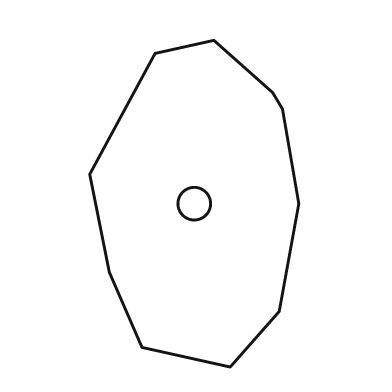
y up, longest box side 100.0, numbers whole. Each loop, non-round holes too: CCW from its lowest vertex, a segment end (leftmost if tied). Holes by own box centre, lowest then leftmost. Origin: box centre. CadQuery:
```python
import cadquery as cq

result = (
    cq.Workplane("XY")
    .moveTo(11.0, -50.0)
    .lineTo(26.0, -33.0)
    .lineTo(32.0, 0.0)
    .lineTo(27.0, 29.0)
    .lineTo(24.0, 34.0)
    .lineTo(6.0, 50.0)
    .lineTo(-12.0, 46.0)
    .lineTo(-32.0, 9.0)
    .lineTo(-26.0, -21.0)
    .lineTo(-16.0, -44.0)
    .close()
    .moveTo(0.0, 0.0)
    .circle(5.0)
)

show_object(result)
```